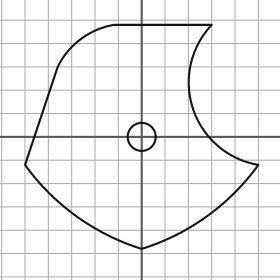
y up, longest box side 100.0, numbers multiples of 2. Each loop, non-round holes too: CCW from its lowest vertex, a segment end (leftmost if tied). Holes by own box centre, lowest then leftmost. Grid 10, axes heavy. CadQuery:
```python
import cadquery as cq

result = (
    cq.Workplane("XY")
    .moveTo(0.0, -48.0)
    .threePointArc((28.0, -34.0), (50.0, -12.0))
    .threePointArc((22.0, 12.0), (30.0, 48.0))
    .lineTo(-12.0, 48.0)
    .threePointArc((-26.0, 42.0), (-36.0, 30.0))
    .lineTo(-50.0, -12.0)
    .threePointArc((-28.0, -34.0), (0.0, -48.0))
    .close()
    .moveTo(0.0, 0.0)
    .circle(6.0)
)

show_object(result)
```